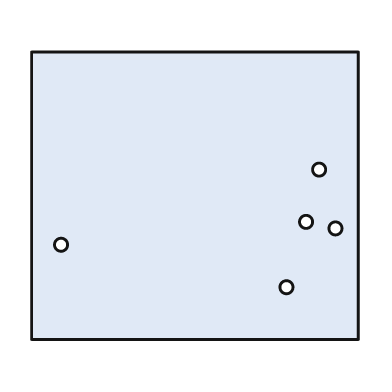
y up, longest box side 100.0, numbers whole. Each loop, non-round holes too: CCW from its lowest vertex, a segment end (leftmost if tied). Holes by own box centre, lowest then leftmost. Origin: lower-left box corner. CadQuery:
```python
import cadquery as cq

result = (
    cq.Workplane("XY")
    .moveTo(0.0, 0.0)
    .lineTo(100.0, 0.0)
    .lineTo(100.0, 88.0)
    .lineTo(0.0, 88.0)
    .close()
    .moveTo(78.0, 16.0)
    .circle(2.0)
    .moveTo(9.0, 29.0)
    .circle(2.0)
    .moveTo(93.0, 34.0)
    .circle(2.0)
    .moveTo(84.0, 36.0)
    .circle(2.0)
    .moveTo(88.0, 52.0)
    .circle(2.0)
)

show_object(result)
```